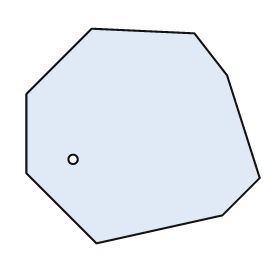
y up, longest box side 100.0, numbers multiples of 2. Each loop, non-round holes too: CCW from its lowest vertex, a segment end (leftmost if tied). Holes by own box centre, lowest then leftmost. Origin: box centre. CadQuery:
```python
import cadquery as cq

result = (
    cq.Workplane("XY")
    .moveTo(-20.0, -46.0)
    .lineTo(34.0, -34.0)
    .lineTo(50.0, -18.0)
    .lineTo(36.0, 26.0)
    .lineTo(22.0, 44.0)
    .lineTo(-22.0, 46.0)
    .lineTo(-50.0, 18.0)
    .lineTo(-50.0, -16.0)
    .close()
    .moveTo(-30.0, -10.0)
    .circle(2.0)
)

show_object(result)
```